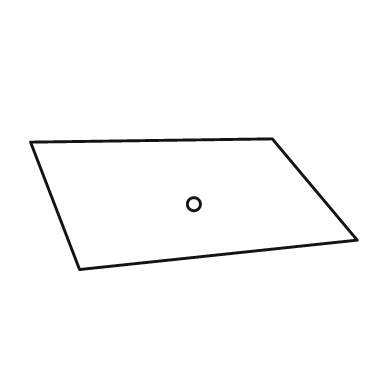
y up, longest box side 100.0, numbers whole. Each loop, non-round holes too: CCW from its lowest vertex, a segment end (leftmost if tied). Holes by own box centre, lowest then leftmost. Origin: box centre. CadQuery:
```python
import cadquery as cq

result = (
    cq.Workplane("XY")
    .moveTo(-35.0, -20.0)
    .lineTo(50.0, -11.0)
    .lineTo(24.0, 20.0)
    .lineTo(-50.0, 19.0)
    .close()
    .moveTo(0.0, 0.0)
    .circle(2.0)
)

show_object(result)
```